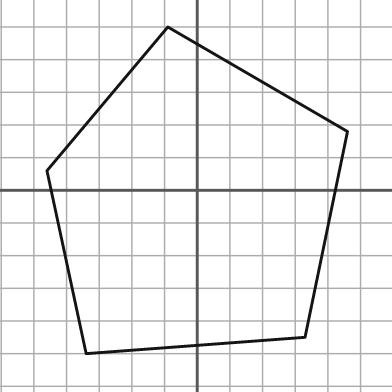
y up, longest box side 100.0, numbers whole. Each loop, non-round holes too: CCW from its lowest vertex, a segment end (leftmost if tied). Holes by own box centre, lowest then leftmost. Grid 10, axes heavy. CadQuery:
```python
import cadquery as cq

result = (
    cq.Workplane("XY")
    .moveTo(-34.0, -50.0)
    .lineTo(33.0, -45.0)
    .lineTo(46.0, 18.0)
    .lineTo(-9.0, 50.0)
    .lineTo(-46.0, 6.0)
    .close()
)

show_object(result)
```